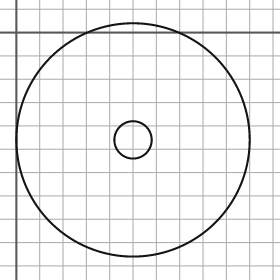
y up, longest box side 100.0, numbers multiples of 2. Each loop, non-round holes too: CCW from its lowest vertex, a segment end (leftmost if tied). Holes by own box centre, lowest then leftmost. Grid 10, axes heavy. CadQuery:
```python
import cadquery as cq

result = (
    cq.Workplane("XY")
    .moveTo(50.0, -46.0)
    .circle(50.0)
    .moveTo(50.0, -46.0)
    .circle(8.0)
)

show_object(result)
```